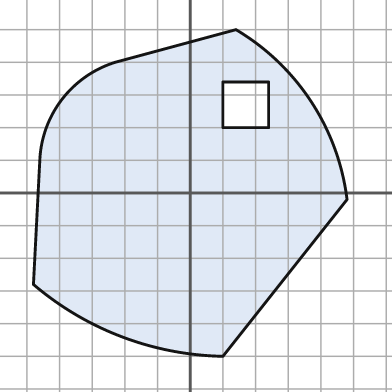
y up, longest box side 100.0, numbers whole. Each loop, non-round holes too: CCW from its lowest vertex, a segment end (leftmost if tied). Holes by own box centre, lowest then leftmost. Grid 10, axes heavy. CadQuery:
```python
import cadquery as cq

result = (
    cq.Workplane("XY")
    .moveTo(10.0, -50.0)
    .lineTo(48.0, -2.0)
    .threePointArc((37.0, 28.0), (14.0, 50.0))
    .lineTo(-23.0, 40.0)
    .threePointArc((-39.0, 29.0), (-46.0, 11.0))
    .lineTo(-48.0, -28.0)
    .threePointArc((-21.0, -44.0), (10.0, -50.0))
    .close()
    .moveTo(10.0, 20.0)
    .lineTo(24.0, 20.0)
    .lineTo(24.0, 34.0)
    .lineTo(10.0, 34.0)
    .close()
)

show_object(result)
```